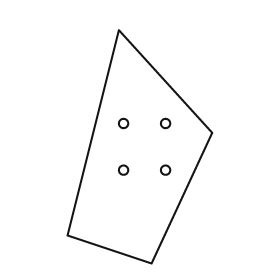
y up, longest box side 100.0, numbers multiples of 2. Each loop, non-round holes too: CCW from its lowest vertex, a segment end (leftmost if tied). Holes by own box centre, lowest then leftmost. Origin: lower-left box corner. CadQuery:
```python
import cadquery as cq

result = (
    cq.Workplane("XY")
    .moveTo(36.0, 0.0)
    .lineTo(62.0, 56.0)
    .lineTo(22.0, 100.0)
    .lineTo(0.0, 12.0)
    .close()
    .moveTo(24.0, 40.0)
    .circle(2.0)
    .moveTo(42.0, 40.0)
    .circle(2.0)
    .moveTo(24.0, 60.0)
    .circle(2.0)
    .moveTo(42.0, 60.0)
    .circle(2.0)
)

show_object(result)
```